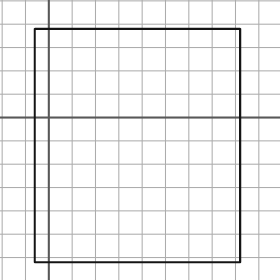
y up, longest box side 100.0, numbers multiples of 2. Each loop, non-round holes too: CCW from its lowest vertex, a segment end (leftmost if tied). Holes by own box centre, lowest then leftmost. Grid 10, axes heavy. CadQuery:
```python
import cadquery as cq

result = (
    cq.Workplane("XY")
    .moveTo(-6.0, -62.0)
    .lineTo(82.0, -62.0)
    .lineTo(82.0, 38.0)
    .lineTo(-6.0, 38.0)
    .close()
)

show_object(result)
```